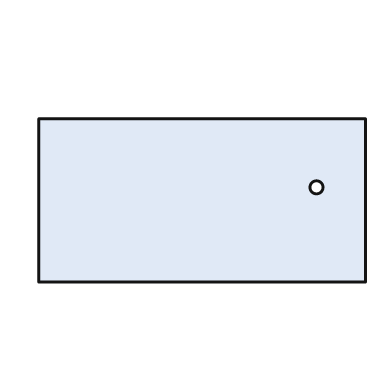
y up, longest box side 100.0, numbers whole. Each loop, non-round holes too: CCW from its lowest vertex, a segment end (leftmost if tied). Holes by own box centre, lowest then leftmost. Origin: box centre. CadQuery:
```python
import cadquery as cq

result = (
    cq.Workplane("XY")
    .moveTo(-50.0, -25.0)
    .lineTo(50.0, -25.0)
    .lineTo(50.0, 25.0)
    .lineTo(-50.0, 25.0)
    .close()
    .moveTo(35.0, 4.0)
    .circle(2.0)
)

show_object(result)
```